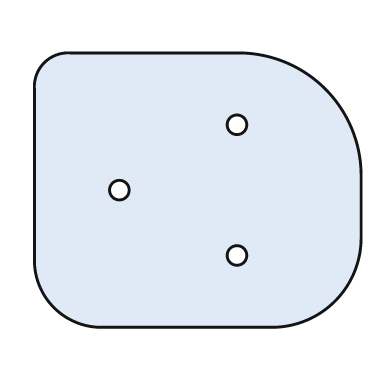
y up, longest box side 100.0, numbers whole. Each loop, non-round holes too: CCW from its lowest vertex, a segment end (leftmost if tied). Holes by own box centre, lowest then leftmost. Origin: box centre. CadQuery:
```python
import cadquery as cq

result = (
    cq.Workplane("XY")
    .moveTo(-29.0, -42.0)
    .lineTo(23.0, -42.0)
    .threePointArc((42.0, -34.0), (50.0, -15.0))
    .lineTo(50.0, 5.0)
    .threePointArc((39.0, 31.0), (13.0, 42.0))
    .lineTo(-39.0, 42.0)
    .threePointArc((-47.0, 39.0), (-50.0, 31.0))
    .lineTo(-50.0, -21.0)
    .threePointArc((-44.0, -36.0), (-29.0, -42.0))
    .close()
    .moveTo(12.0, -20.0)
    .circle(3.0)
    .moveTo(-24.0, 0.0)
    .circle(3.0)
    .moveTo(12.0, 20.0)
    .circle(3.0)
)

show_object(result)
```